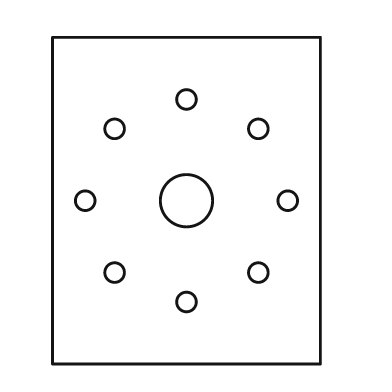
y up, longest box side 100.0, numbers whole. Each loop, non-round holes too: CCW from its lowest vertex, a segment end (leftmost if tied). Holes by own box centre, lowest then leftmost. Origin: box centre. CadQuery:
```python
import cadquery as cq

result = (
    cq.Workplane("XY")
    .moveTo(-41.0, -50.0)
    .lineTo(41.0, -50.0)
    .lineTo(41.0, 50.0)
    .lineTo(-41.0, 50.0)
    .close()
    .moveTo(0.0, -31.0)
    .circle(3.0)
    .moveTo(-22.0, -22.0)
    .circle(3.0)
    .moveTo(22.0, -22.0)
    .circle(3.0)
    .moveTo(-31.0, 0.0)
    .circle(3.0)
    .moveTo(0.0, 0.0)
    .circle(8.0)
    .moveTo(31.0, 0.0)
    .circle(3.0)
    .moveTo(-22.0, 22.0)
    .circle(3.0)
    .moveTo(22.0, 22.0)
    .circle(3.0)
    .moveTo(0.0, 31.0)
    .circle(3.0)
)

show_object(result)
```